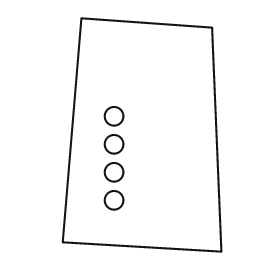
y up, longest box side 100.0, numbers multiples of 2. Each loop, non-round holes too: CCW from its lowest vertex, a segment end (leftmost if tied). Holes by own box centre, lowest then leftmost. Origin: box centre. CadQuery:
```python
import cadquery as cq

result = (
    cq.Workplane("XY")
    .moveTo(34.0, -50.0)
    .lineTo(30.0, 46.0)
    .lineTo(-26.0, 50.0)
    .lineTo(-34.0, -46.0)
    .close()
    .moveTo(-12.0, -28.0)
    .circle(4.0)
    .moveTo(-12.0, -16.0)
    .circle(4.0)
    .moveTo(-12.0, -4.0)
    .circle(4.0)
    .moveTo(-12.0, 8.0)
    .circle(4.0)
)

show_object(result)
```